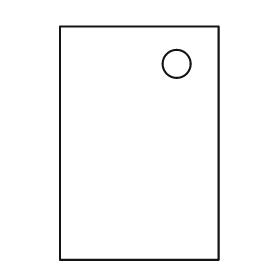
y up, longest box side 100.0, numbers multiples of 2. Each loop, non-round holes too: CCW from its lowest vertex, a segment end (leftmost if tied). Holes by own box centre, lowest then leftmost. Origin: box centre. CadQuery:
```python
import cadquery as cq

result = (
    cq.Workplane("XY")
    .moveTo(-34.0, -50.0)
    .lineTo(34.0, -50.0)
    .lineTo(34.0, 50.0)
    .lineTo(-34.0, 50.0)
    .close()
    .moveTo(16.0, 34.0)
    .circle(6.0)
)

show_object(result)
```